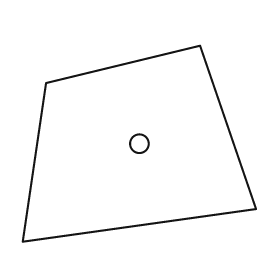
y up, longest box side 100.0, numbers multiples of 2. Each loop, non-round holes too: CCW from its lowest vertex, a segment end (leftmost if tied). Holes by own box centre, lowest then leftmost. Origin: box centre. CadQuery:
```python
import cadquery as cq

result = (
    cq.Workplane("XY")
    .moveTo(-50.0, -42.0)
    .lineTo(50.0, -28.0)
    .lineTo(26.0, 42.0)
    .lineTo(-40.0, 26.0)
    .close()
    .moveTo(0.0, 0.0)
    .circle(4.0)
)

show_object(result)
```